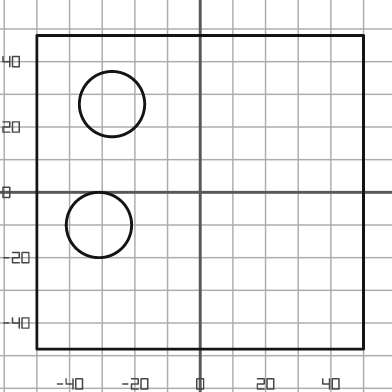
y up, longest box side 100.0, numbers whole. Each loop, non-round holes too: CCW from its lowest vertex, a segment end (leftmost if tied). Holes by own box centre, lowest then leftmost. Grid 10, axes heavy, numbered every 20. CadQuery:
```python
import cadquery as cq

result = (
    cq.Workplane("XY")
    .moveTo(-50.0, -48.0)
    .lineTo(50.0, -48.0)
    .lineTo(50.0, 48.0)
    .lineTo(-50.0, 48.0)
    .close()
    .moveTo(-31.0, -10.0)
    .circle(10.0)
    .moveTo(-27.0, 27.0)
    .circle(10.0)
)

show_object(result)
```